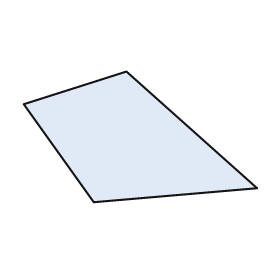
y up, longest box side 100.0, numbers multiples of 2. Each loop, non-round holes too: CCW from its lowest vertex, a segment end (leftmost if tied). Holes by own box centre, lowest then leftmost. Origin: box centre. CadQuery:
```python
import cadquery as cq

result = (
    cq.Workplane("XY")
    .moveTo(-20.0, -28.0)
    .lineTo(50.0, -22.0)
    .lineTo(-6.0, 28.0)
    .lineTo(-50.0, 14.0)
    .close()
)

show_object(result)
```